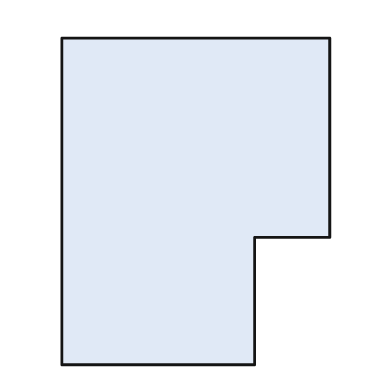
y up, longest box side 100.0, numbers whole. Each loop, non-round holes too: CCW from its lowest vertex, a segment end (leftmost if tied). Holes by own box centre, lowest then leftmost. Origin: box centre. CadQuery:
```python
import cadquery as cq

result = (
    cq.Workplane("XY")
    .moveTo(-41.0, -50.0)
    .lineTo(18.0, -50.0)
    .lineTo(18.0, -11.0)
    .lineTo(41.0, -11.0)
    .lineTo(41.0, 50.0)
    .lineTo(-41.0, 50.0)
    .close()
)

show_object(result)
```